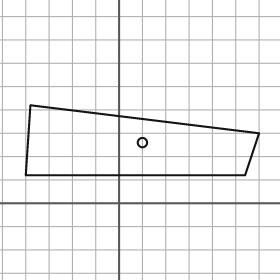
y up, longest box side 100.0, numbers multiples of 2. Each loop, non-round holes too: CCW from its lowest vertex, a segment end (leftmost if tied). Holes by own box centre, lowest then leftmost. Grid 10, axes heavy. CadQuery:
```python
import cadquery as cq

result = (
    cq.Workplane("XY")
    .moveTo(-40.0, 12.0)
    .lineTo(54.0, 12.0)
    .lineTo(60.0, 30.0)
    .lineTo(-38.0, 42.0)
    .close()
    .moveTo(10.0, 26.0)
    .circle(2.0)
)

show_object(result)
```